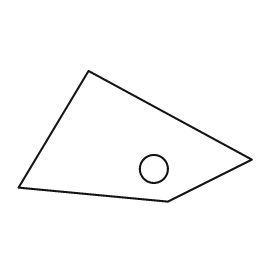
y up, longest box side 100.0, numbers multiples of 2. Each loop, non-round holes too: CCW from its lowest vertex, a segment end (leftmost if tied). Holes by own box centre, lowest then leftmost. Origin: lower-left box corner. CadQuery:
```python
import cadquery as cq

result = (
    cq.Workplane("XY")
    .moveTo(64.0, 0.0)
    .lineTo(100.0, 18.0)
    .lineTo(30.0, 56.0)
    .lineTo(0.0, 6.0)
    .close()
    .moveTo(58.0, 14.0)
    .circle(6.0)
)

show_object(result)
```